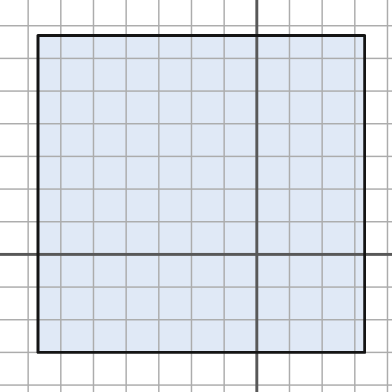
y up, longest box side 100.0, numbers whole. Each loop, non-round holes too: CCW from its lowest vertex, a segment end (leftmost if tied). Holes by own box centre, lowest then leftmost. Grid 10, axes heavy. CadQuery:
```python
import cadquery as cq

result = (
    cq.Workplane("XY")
    .moveTo(-67.0, -30.0)
    .lineTo(33.0, -30.0)
    .lineTo(33.0, 67.0)
    .lineTo(-67.0, 67.0)
    .close()
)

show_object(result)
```